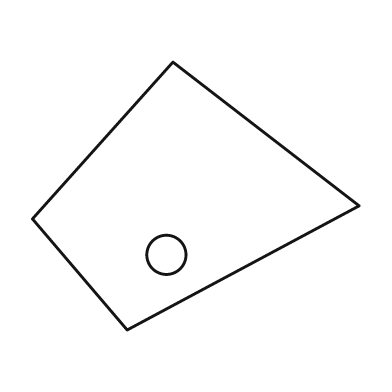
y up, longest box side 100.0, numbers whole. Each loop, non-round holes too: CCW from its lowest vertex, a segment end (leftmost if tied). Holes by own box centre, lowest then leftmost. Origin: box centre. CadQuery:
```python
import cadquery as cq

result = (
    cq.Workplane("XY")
    .moveTo(-21.0, -41.0)
    .lineTo(50.0, -3.0)
    .lineTo(-7.0, 41.0)
    .lineTo(-50.0, -7.0)
    .close()
    .moveTo(-9.0, -18.0)
    .circle(6.0)
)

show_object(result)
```